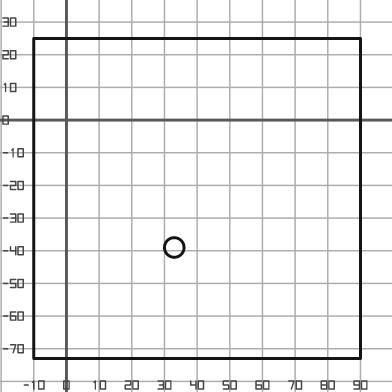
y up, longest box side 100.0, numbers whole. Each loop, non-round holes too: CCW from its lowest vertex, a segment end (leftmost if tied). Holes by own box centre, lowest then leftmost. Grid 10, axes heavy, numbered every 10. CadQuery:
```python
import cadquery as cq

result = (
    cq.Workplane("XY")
    .moveTo(-10.0, -73.0)
    .lineTo(90.0, -73.0)
    .lineTo(90.0, 25.0)
    .lineTo(-10.0, 25.0)
    .close()
    .moveTo(33.0, -39.0)
    .circle(3.0)
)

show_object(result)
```